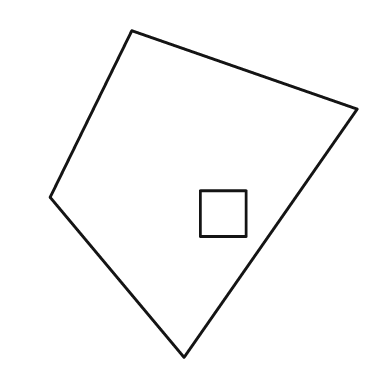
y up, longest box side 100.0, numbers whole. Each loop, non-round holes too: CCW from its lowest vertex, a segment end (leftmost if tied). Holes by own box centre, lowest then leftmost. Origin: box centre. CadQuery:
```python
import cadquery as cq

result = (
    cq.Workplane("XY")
    .moveTo(-6.0, -50.0)
    .lineTo(47.0, 26.0)
    .lineTo(-22.0, 50.0)
    .lineTo(-47.0, -1.0)
    .close()
    .moveTo(-1.0, -13.0)
    .lineTo(13.0, -13.0)
    .lineTo(13.0, 1.0)
    .lineTo(-1.0, 1.0)
    .close()
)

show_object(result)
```